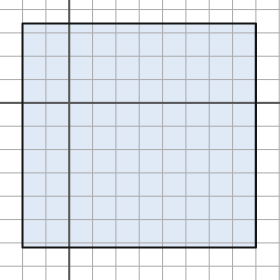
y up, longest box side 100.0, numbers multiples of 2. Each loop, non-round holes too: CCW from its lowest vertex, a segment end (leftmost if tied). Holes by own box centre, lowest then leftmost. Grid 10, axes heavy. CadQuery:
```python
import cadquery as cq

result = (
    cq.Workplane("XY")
    .moveTo(-20.0, -62.0)
    .lineTo(80.0, -62.0)
    .lineTo(80.0, 34.0)
    .lineTo(-20.0, 34.0)
    .close()
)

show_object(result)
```